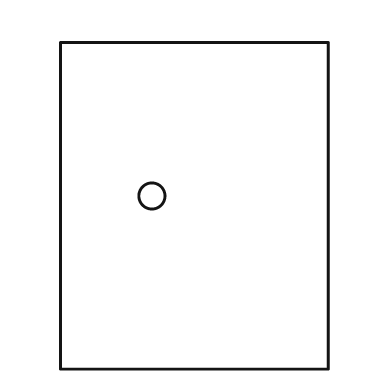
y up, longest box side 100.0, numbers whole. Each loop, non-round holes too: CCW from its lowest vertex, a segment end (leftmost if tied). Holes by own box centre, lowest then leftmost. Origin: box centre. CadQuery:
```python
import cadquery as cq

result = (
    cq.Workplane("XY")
    .moveTo(-41.0, -50.0)
    .lineTo(41.0, -50.0)
    .lineTo(41.0, 50.0)
    .lineTo(-41.0, 50.0)
    .close()
    .moveTo(-13.0, 3.0)
    .circle(4.0)
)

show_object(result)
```